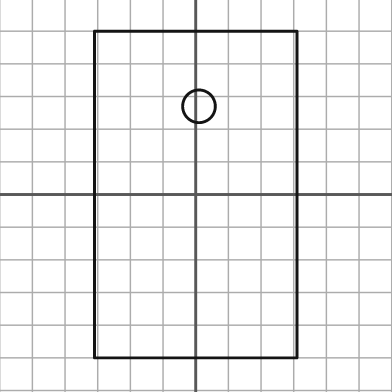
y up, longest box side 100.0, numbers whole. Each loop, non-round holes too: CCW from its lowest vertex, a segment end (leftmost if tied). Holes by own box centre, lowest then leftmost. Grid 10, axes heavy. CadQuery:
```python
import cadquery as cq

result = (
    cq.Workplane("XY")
    .moveTo(-31.0, -50.0)
    .lineTo(31.0, -50.0)
    .lineTo(31.0, 50.0)
    .lineTo(-31.0, 50.0)
    .close()
    .moveTo(1.0, 27.0)
    .circle(5.0)
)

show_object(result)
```